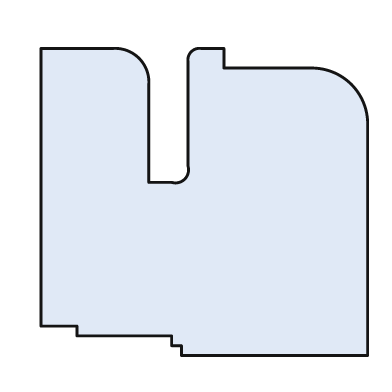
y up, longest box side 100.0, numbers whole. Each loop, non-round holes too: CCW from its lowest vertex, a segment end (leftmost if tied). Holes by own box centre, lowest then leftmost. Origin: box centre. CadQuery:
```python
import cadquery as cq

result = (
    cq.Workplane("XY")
    .moveTo(-7.0, -47.0)
    .lineTo(50.0, -47.0)
    .lineTo(50.0, 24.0)
    .threePointArc((45.0, 36.0), (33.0, 41.0))
    .lineTo(6.0, 41.0)
    .lineTo(6.0, 47.0)
    .lineTo(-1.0, 47.0)
    .threePointArc((-4.0, 46.0), (-5.0, 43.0))
    .lineTo(-5.0, 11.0)
    .threePointArc((-6.0, 7.0), (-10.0, 6.0))
    .lineTo(-17.0, 6.0)
    .lineTo(-17.0, 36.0)
    .threePointArc((-20.0, 44.0), (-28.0, 47.0))
    .lineTo(-50.0, 47.0)
    .lineTo(-50.0, -38.0)
    .lineTo(-39.0, -38.0)
    .lineTo(-39.0, -41.0)
    .lineTo(-10.0, -41.0)
    .lineTo(-10.0, -44.0)
    .lineTo(-7.0, -44.0)
    .close()
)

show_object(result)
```